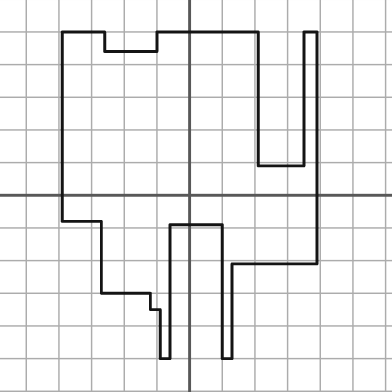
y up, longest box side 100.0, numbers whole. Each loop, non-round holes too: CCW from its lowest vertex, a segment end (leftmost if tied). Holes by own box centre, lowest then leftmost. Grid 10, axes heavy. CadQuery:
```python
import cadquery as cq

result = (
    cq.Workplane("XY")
    .moveTo(-9.0, -50.0)
    .lineTo(-6.0, -50.0)
    .lineTo(-6.0, -9.0)
    .lineTo(10.0, -9.0)
    .lineTo(10.0, -50.0)
    .lineTo(13.0, -50.0)
    .lineTo(13.0, -21.0)
    .lineTo(39.0, -21.0)
    .lineTo(39.0, 50.0)
    .lineTo(35.0, 50.0)
    .lineTo(35.0, 9.0)
    .lineTo(21.0, 9.0)
    .lineTo(21.0, 50.0)
    .lineTo(-10.0, 50.0)
    .lineTo(-10.0, 44.0)
    .lineTo(-26.0, 44.0)
    .lineTo(-26.0, 50.0)
    .lineTo(-39.0, 50.0)
    .lineTo(-39.0, -8.0)
    .lineTo(-27.0, -8.0)
    .lineTo(-27.0, -30.0)
    .lineTo(-12.0, -30.0)
    .lineTo(-12.0, -35.0)
    .lineTo(-9.0, -35.0)
    .close()
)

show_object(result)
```